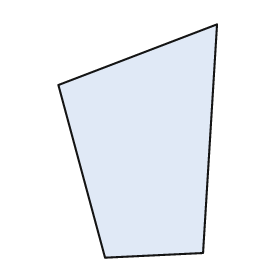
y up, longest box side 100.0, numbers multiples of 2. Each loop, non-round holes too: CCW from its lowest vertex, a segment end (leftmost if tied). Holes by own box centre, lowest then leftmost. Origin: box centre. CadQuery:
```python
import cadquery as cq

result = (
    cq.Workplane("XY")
    .moveTo(-14.0, -50.0)
    .lineTo(28.0, -48.0)
    .lineTo(34.0, 50.0)
    .lineTo(-34.0, 24.0)
    .close()
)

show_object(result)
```